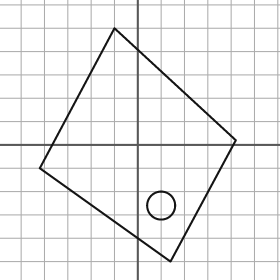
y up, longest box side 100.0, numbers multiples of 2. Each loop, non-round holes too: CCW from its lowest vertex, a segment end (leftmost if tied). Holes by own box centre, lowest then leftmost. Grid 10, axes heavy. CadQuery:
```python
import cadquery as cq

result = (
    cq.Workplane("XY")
    .moveTo(14.0, -50.0)
    .lineTo(42.0, 2.0)
    .lineTo(-10.0, 50.0)
    .lineTo(-42.0, -10.0)
    .close()
    .moveTo(10.0, -26.0)
    .circle(6.0)
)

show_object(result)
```